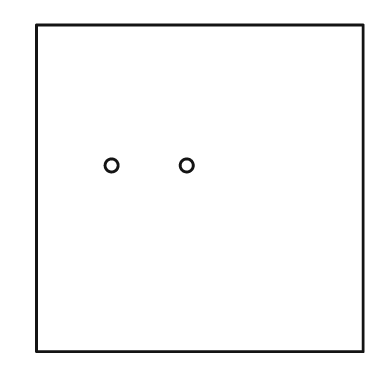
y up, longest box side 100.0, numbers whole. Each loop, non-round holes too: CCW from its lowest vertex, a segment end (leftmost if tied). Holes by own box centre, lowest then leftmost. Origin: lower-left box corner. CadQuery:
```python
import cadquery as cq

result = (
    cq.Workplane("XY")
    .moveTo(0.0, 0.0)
    .lineTo(100.0, 0.0)
    .lineTo(100.0, 100.0)
    .lineTo(0.0, 100.0)
    .close()
    .moveTo(23.0, 57.0)
    .circle(2.0)
    .moveTo(46.0, 57.0)
    .circle(2.0)
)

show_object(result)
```